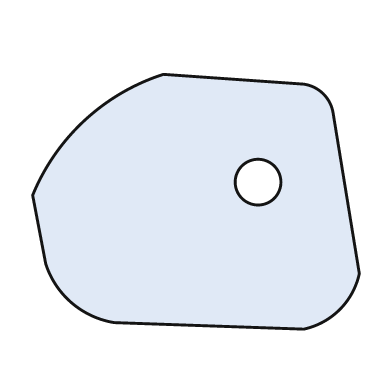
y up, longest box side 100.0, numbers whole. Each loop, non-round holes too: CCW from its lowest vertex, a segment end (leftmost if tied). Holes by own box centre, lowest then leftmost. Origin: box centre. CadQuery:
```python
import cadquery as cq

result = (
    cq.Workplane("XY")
    .moveTo(33.0, -39.0)
    .threePointArc((44.0, -33.0), (50.0, -22.0))
    .lineTo(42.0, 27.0)
    .threePointArc((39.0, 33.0), (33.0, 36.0))
    .lineTo(-10.0, 39.0)
    .threePointArc((-34.0, 25.0), (-50.0, 2.0))
    .lineTo(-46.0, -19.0)
    .threePointArc((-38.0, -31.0), (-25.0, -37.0))
    .close()
    .moveTo(19.0, 6.0)
    .circle(7.0)
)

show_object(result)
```